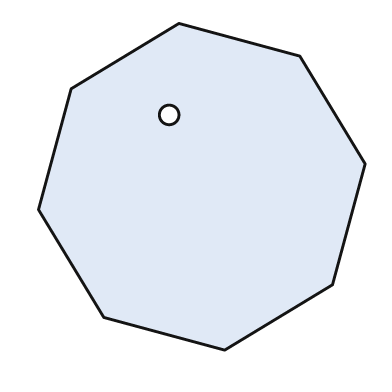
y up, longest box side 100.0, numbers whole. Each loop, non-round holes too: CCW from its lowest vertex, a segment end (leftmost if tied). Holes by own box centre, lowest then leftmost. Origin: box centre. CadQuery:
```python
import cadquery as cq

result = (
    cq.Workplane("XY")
    .moveTo(7.0, -50.0)
    .lineTo(40.0, -30.0)
    .lineTo(50.0, 7.0)
    .lineTo(30.0, 40.0)
    .lineTo(-7.0, 50.0)
    .lineTo(-40.0, 30.0)
    .lineTo(-50.0, -7.0)
    .lineTo(-30.0, -40.0)
    .close()
    .moveTo(-10.0, 22.0)
    .circle(3.0)
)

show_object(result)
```